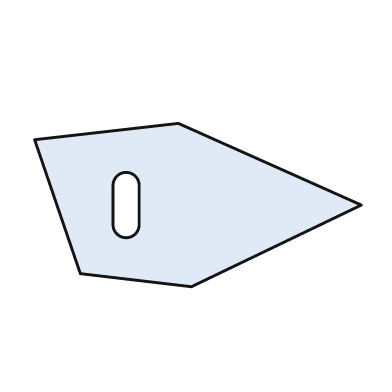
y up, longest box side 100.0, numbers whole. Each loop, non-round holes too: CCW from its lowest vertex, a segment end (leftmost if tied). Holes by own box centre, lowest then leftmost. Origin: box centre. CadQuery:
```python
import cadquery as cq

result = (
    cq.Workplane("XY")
    .moveTo(-2.0, -25.0)
    .lineTo(50.0, 0.0)
    .lineTo(-6.0, 25.0)
    .lineTo(-50.0, 20.0)
    .lineTo(-36.0, -21.0)
    .close()
    .moveTo(-26.0, -6.0)
    .threePointArc((-22.0, -10.0), (-18.0, -6.0))
    .lineTo(-18.0, 6.0)
    .threePointArc((-22.0, 10.0), (-26.0, 6.0))
    .close()
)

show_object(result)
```